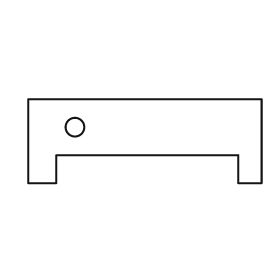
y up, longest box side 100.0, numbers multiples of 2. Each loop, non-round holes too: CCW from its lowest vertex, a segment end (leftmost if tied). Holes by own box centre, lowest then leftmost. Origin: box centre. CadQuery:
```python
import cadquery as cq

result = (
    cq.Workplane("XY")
    .moveTo(-50.0, -18.0)
    .lineTo(-38.0, -18.0)
    .lineTo(-38.0, -6.0)
    .lineTo(40.0, -6.0)
    .lineTo(40.0, -18.0)
    .lineTo(50.0, -18.0)
    .lineTo(50.0, 18.0)
    .lineTo(-50.0, 18.0)
    .close()
    .moveTo(-30.0, 6.0)
    .circle(4.0)
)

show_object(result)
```